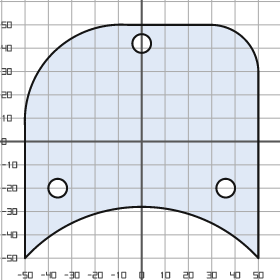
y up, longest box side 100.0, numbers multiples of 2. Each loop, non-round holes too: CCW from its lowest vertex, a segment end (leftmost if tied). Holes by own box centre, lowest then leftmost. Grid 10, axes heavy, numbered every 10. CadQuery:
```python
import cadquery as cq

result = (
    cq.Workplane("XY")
    .moveTo(-50.0, -50.0)
    .threePointArc((0.0, -28.0), (50.0, -50.0))
    .lineTo(50.0, 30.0)
    .threePointArc((44.0, 44.0), (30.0, 50.0))
    .lineTo(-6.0, 50.0)
    .threePointArc((-38.0, 38.0), (-50.0, 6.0))
    .close()
    .moveTo(-36.0, -20.0)
    .circle(4.0)
    .moveTo(36.0, -20.0)
    .circle(4.0)
    .moveTo(0.0, 42.0)
    .circle(4.0)
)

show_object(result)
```